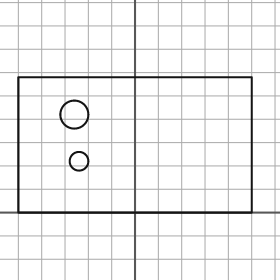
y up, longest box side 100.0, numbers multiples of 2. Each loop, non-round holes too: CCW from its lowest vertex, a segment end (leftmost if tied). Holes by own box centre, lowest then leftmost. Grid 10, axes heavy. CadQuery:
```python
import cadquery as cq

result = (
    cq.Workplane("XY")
    .moveTo(-50.0, 0.0)
    .lineTo(50.0, 0.0)
    .lineTo(50.0, 58.0)
    .lineTo(-50.0, 58.0)
    .close()
    .moveTo(-24.0, 22.0)
    .circle(4.0)
    .moveTo(-26.0, 42.0)
    .circle(6.0)
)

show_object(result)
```